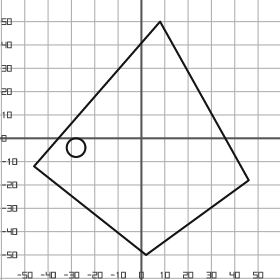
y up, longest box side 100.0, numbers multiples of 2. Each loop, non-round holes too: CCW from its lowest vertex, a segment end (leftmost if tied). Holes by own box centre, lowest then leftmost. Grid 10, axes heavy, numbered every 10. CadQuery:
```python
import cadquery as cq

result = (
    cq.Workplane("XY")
    .moveTo(2.0, -50.0)
    .lineTo(46.0, -18.0)
    .lineTo(8.0, 50.0)
    .lineTo(-46.0, -12.0)
    .close()
    .moveTo(-28.0, -4.0)
    .circle(4.0)
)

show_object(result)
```